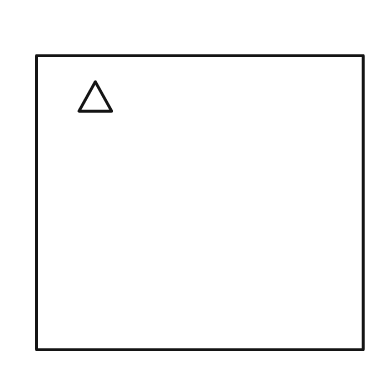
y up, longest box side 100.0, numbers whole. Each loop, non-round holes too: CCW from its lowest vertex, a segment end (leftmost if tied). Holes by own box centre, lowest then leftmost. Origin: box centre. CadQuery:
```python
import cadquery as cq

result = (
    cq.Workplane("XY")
    .moveTo(-50.0, -45.0)
    .lineTo(50.0, -45.0)
    .lineTo(50.0, 45.0)
    .lineTo(-50.0, 45.0)
    .close()
    .moveTo(-37.0, 28.0)
    .lineTo(-27.0, 28.0)
    .lineTo(-32.0, 37.0)
    .close()
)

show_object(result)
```